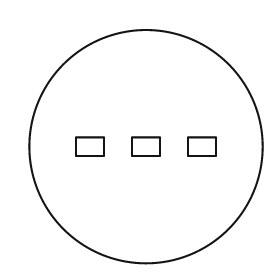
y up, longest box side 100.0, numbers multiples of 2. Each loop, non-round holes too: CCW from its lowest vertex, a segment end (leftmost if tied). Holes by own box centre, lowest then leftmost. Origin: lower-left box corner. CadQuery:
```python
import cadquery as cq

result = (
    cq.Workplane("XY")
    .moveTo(50.0, 50.0)
    .circle(50.0)
    .moveTo(20.0, 46.0)
    .lineTo(32.0, 46.0)
    .lineTo(32.0, 54.0)
    .lineTo(20.0, 54.0)
    .close()
    .moveTo(44.0, 46.0)
    .lineTo(56.0, 46.0)
    .lineTo(56.0, 54.0)
    .lineTo(44.0, 54.0)
    .close()
    .moveTo(68.0, 46.0)
    .lineTo(80.0, 46.0)
    .lineTo(80.0, 54.0)
    .lineTo(68.0, 54.0)
    .close()
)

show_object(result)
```